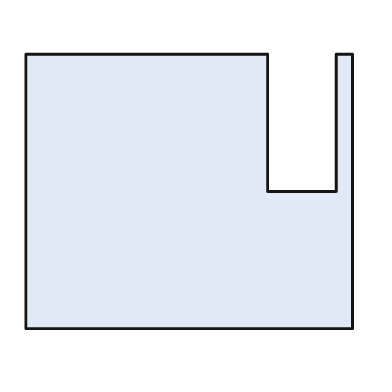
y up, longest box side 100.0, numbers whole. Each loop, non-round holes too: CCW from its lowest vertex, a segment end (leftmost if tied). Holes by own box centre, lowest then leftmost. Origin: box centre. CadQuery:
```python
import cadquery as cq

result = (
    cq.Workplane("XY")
    .moveTo(-50.0, -42.0)
    .lineTo(50.0, -42.0)
    .lineTo(50.0, 42.0)
    .lineTo(45.0, 42.0)
    .lineTo(45.0, 0.0)
    .lineTo(24.0, 0.0)
    .lineTo(24.0, 42.0)
    .lineTo(-50.0, 42.0)
    .close()
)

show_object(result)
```